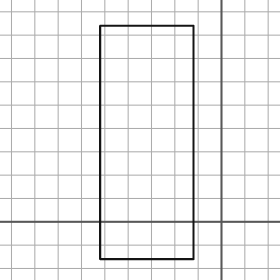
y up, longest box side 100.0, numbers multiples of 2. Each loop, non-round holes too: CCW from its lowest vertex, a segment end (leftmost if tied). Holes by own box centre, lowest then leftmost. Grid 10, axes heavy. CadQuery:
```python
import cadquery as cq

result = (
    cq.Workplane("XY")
    .moveTo(-52.0, -16.0)
    .lineTo(-12.0, -16.0)
    .lineTo(-12.0, 84.0)
    .lineTo(-52.0, 84.0)
    .close()
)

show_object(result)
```